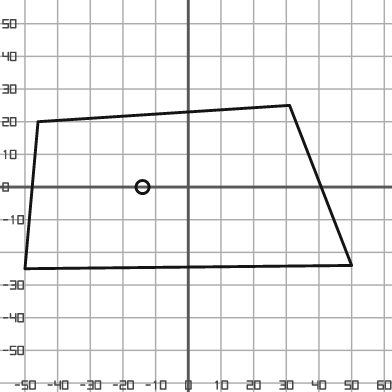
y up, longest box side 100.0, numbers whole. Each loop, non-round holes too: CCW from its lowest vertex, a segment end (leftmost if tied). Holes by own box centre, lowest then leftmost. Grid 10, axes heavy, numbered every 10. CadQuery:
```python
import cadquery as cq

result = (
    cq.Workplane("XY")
    .moveTo(-50.0, -25.0)
    .lineTo(50.0, -24.0)
    .lineTo(31.0, 25.0)
    .lineTo(-46.0, 20.0)
    .close()
    .moveTo(-14.0, 0.0)
    .circle(2.0)
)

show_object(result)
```